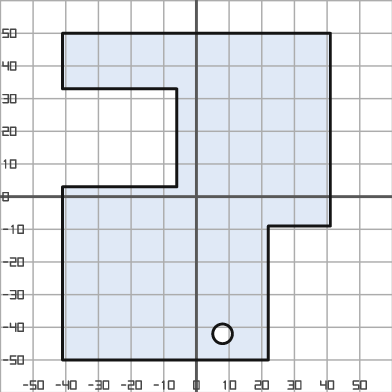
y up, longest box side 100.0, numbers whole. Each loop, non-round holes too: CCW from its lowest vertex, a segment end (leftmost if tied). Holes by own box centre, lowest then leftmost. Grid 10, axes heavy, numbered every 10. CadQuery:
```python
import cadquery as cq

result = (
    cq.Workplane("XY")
    .moveTo(-41.0, -50.0)
    .lineTo(22.0, -50.0)
    .lineTo(22.0, -9.0)
    .lineTo(41.0, -9.0)
    .lineTo(41.0, 50.0)
    .lineTo(-41.0, 50.0)
    .lineTo(-41.0, 33.0)
    .lineTo(-6.0, 33.0)
    .lineTo(-6.0, 3.0)
    .lineTo(-41.0, 3.0)
    .close()
    .moveTo(8.0, -42.0)
    .circle(3.0)
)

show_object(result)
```